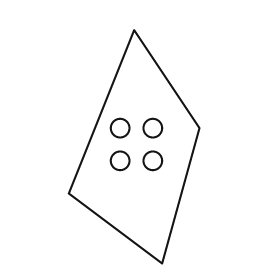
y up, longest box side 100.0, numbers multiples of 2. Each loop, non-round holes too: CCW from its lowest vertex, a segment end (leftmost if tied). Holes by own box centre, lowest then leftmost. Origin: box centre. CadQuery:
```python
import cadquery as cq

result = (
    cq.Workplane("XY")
    .moveTo(12.0, -50.0)
    .lineTo(28.0, 8.0)
    .lineTo(0.0, 50.0)
    .lineTo(-28.0, -20.0)
    .close()
    .moveTo(-6.0, -6.0)
    .circle(4.0)
    .moveTo(8.0, -6.0)
    .circle(4.0)
    .moveTo(-6.0, 8.0)
    .circle(4.0)
    .moveTo(8.0, 8.0)
    .circle(4.0)
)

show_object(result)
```